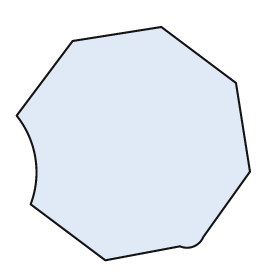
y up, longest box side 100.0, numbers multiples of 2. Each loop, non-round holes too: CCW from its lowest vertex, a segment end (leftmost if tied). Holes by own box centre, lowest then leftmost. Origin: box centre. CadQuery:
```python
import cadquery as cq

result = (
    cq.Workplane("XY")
    .moveTo(-12.0, -50.0)
    .lineTo(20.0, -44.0)
    .threePointArc((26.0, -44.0), (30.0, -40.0))
    .lineTo(50.0, -12.0)
    .lineTo(44.0, 26.0)
    .lineTo(12.0, 50.0)
    .lineTo(-26.0, 44.0)
    .lineTo(-50.0, 12.0)
    .threePointArc((-42.0, -6.0), (-44.0, -26.0))
    .close()
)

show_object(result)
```